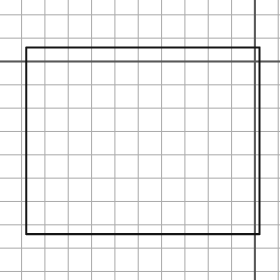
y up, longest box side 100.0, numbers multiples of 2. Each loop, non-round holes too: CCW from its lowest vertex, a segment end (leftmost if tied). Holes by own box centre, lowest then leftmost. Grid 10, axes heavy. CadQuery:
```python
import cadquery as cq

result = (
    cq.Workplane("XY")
    .moveTo(-98.0, -74.0)
    .lineTo(2.0, -74.0)
    .lineTo(2.0, 6.0)
    .lineTo(-98.0, 6.0)
    .close()
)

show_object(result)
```